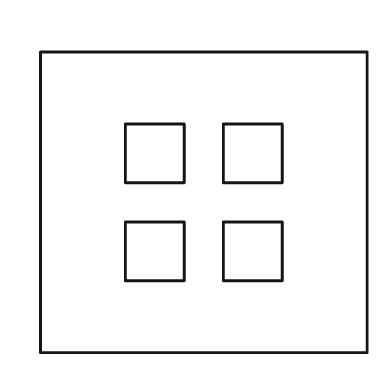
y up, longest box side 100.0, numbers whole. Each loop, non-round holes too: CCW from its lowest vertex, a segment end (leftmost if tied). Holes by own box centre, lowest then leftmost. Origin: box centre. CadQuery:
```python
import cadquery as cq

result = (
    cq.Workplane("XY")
    .moveTo(-50.0, -46.0)
    .lineTo(50.0, -46.0)
    .lineTo(50.0, 46.0)
    .lineTo(-50.0, 46.0)
    .close()
    .moveTo(-24.0, -24.0)
    .lineTo(-6.0, -24.0)
    .lineTo(-6.0, -6.0)
    .lineTo(-24.0, -6.0)
    .close()
    .moveTo(6.0, -24.0)
    .lineTo(24.0, -24.0)
    .lineTo(24.0, -6.0)
    .lineTo(6.0, -6.0)
    .close()
    .moveTo(-24.0, 6.0)
    .lineTo(-6.0, 6.0)
    .lineTo(-6.0, 24.0)
    .lineTo(-24.0, 24.0)
    .close()
    .moveTo(6.0, 6.0)
    .lineTo(24.0, 6.0)
    .lineTo(24.0, 24.0)
    .lineTo(6.0, 24.0)
    .close()
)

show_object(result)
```